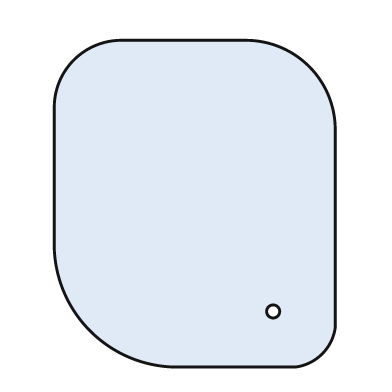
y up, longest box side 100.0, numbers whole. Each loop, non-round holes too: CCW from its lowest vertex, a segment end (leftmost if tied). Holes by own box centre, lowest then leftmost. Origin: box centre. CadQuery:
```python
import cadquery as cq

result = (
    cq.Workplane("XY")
    .moveTo(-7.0, -50.0)
    .lineTo(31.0, -50.0)
    .threePointArc((39.0, -46.0), (43.0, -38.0))
    .lineTo(43.0, 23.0)
    .threePointArc((35.0, 42.0), (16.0, 50.0))
    .lineTo(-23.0, 50.0)
    .threePointArc((-37.0, 44.0), (-43.0, 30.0))
    .lineTo(-43.0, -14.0)
    .threePointArc((-32.0, -39.0), (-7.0, -50.0))
    .close()
    .moveTo(24.0, -33.0)
    .circle(2.0)
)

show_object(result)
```